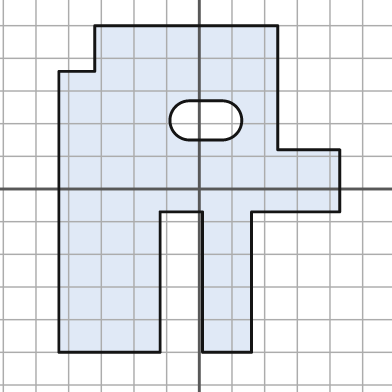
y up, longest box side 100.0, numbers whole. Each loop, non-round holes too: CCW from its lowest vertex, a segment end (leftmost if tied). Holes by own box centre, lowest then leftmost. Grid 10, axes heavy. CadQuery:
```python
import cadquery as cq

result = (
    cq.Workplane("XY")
    .moveTo(-43.0, -50.0)
    .lineTo(-12.0, -50.0)
    .lineTo(-12.0, -7.0)
    .lineTo(1.0, -7.0)
    .lineTo(1.0, -50.0)
    .lineTo(16.0, -50.0)
    .lineTo(16.0, -7.0)
    .lineTo(43.0, -7.0)
    .lineTo(43.0, 12.0)
    .lineTo(24.0, 12.0)
    .lineTo(24.0, 50.0)
    .lineTo(-32.0, 50.0)
    .lineTo(-32.0, 36.0)
    .lineTo(-43.0, 36.0)
    .close()
    .moveTo(-3.0, 15.0)
    .lineTo(7.0, 15.0)
    .threePointArc((13.0, 21.0), (7.0, 27.0))
    .lineTo(-3.0, 27.0)
    .threePointArc((-9.0, 21.0), (-3.0, 15.0))
    .close()
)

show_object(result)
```